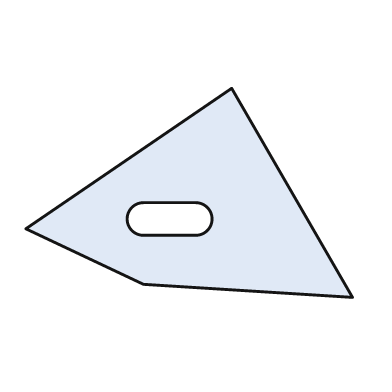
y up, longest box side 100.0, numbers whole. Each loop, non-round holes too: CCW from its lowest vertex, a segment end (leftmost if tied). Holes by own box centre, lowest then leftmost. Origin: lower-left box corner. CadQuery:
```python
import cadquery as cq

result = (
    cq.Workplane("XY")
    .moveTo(100.0, 0.0)
    .lineTo(63.0, 64.0)
    .lineTo(0.0, 21.0)
    .lineTo(36.0, 4.0)
    .close()
    .moveTo(36.0, 19.0)
    .lineTo(52.0, 19.0)
    .threePointArc((57.0, 24.0), (52.0, 29.0))
    .lineTo(36.0, 29.0)
    .threePointArc((31.0, 24.0), (36.0, 19.0))
    .close()
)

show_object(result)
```